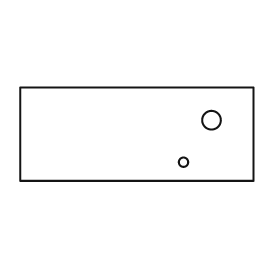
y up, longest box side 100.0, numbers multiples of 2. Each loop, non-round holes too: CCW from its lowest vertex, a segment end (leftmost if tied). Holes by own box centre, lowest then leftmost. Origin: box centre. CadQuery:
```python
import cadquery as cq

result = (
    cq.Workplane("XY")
    .moveTo(-50.0, -20.0)
    .lineTo(50.0, -20.0)
    .lineTo(50.0, 20.0)
    .lineTo(-50.0, 20.0)
    .close()
    .moveTo(20.0, -12.0)
    .circle(2.0)
    .moveTo(32.0, 6.0)
    .circle(4.0)
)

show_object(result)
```